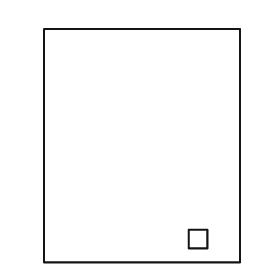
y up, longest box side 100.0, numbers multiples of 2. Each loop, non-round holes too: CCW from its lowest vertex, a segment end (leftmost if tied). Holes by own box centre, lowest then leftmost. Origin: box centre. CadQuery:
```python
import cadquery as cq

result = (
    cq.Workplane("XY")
    .moveTo(-42.0, -50.0)
    .lineTo(42.0, -50.0)
    .lineTo(42.0, 50.0)
    .lineTo(-42.0, 50.0)
    .close()
    .moveTo(20.0, -44.0)
    .lineTo(28.0, -44.0)
    .lineTo(28.0, -36.0)
    .lineTo(20.0, -36.0)
    .close()
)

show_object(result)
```